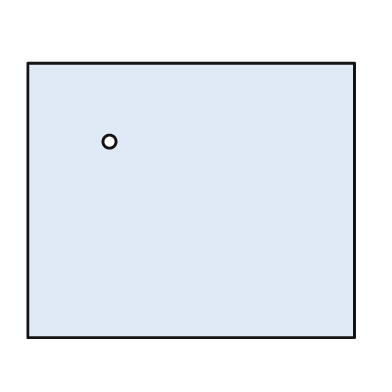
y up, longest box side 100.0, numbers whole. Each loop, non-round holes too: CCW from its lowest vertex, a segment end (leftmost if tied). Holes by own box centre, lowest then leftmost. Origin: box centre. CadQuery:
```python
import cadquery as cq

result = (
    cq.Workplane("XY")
    .moveTo(-50.0, -42.0)
    .lineTo(50.0, -42.0)
    .lineTo(50.0, 42.0)
    .lineTo(-50.0, 42.0)
    .close()
    .moveTo(-25.0, 18.0)
    .circle(2.0)
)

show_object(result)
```